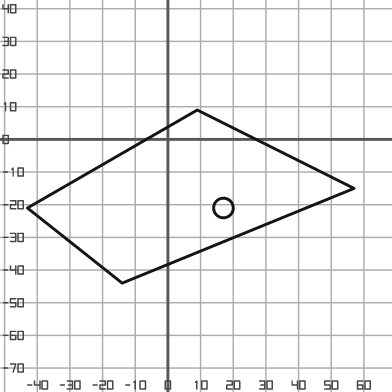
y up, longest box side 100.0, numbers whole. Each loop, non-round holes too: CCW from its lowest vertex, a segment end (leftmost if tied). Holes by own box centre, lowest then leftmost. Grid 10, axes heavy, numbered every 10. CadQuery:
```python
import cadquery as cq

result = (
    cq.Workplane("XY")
    .moveTo(-14.0, -44.0)
    .lineTo(57.0, -15.0)
    .lineTo(9.0, 9.0)
    .lineTo(-43.0, -21.0)
    .close()
    .moveTo(17.0, -21.0)
    .circle(3.0)
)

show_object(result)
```